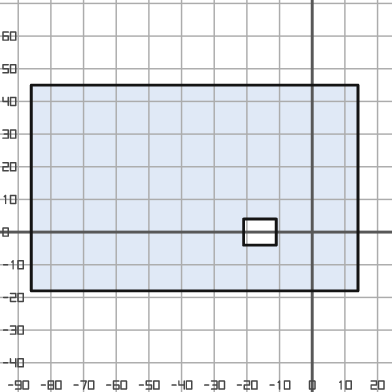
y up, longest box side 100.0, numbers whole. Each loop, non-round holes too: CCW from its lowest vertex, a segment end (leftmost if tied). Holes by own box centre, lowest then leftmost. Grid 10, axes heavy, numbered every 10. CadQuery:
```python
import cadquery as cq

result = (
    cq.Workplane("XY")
    .moveTo(-86.0, -18.0)
    .lineTo(14.0, -18.0)
    .lineTo(14.0, 45.0)
    .lineTo(-86.0, 45.0)
    .close()
    .moveTo(-21.0, -4.0)
    .lineTo(-11.0, -4.0)
    .lineTo(-11.0, 4.0)
    .lineTo(-21.0, 4.0)
    .close()
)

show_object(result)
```